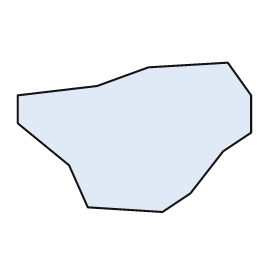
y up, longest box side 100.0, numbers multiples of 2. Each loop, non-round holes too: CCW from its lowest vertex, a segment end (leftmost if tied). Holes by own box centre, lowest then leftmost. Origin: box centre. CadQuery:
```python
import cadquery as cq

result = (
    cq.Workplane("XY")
    .moveTo(12.0, -32.0)
    .lineTo(24.0, -24.0)
    .lineTo(38.0, -6.0)
    .lineTo(50.0, 2.0)
    .lineTo(50.0, 18.0)
    .lineTo(40.0, 32.0)
    .lineTo(6.0, 30.0)
    .lineTo(-16.0, 22.0)
    .lineTo(-50.0, 18.0)
    .lineTo(-50.0, 6.0)
    .lineTo(-28.0, -12.0)
    .lineTo(-20.0, -30.0)
    .close()
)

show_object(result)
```